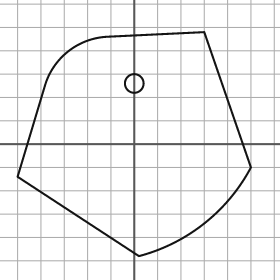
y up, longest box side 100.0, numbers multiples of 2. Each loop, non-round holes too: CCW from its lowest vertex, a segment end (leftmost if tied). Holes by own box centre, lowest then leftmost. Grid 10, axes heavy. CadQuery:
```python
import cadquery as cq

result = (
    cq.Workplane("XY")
    .moveTo(2.0, -48.0)
    .threePointArc((30.0, -34.0), (50.0, -10.0))
    .lineTo(30.0, 48.0)
    .lineTo(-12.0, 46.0)
    .threePointArc((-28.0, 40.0), (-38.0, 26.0))
    .lineTo(-50.0, -14.0)
    .close()
    .moveTo(0.0, 26.0)
    .circle(4.0)
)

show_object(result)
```